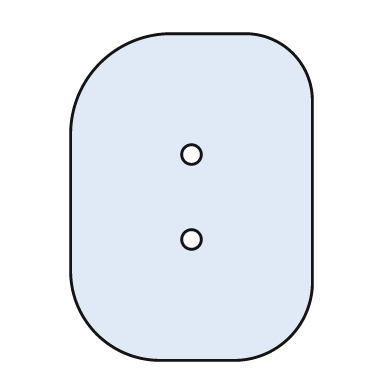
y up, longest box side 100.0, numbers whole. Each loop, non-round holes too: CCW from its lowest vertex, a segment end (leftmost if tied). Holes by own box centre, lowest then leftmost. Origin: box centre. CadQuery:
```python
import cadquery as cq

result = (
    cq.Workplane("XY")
    .moveTo(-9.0, -50.0)
    .lineTo(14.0, -50.0)
    .threePointArc((30.0, -43.0), (37.0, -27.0))
    .lineTo(37.0, 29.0)
    .threePointArc((31.0, 44.0), (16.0, 50.0))
    .lineTo(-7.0, 50.0)
    .threePointArc((-28.0, 41.0), (-37.0, 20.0))
    .lineTo(-37.0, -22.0)
    .threePointArc((-29.0, -42.0), (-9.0, -50.0))
    .close()
    .moveTo(0.0, -13.0)
    .circle(3.0)
    .moveTo(0.0, 13.0)
    .circle(3.0)
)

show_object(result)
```